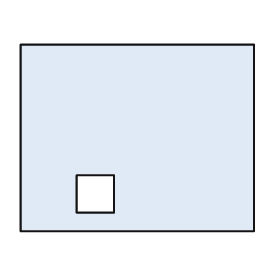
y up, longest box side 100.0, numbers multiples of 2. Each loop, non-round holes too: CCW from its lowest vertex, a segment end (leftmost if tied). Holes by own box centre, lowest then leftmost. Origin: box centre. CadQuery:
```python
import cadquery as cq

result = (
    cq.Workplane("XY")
    .moveTo(-50.0, -40.0)
    .lineTo(50.0, -40.0)
    .lineTo(50.0, 40.0)
    .lineTo(-50.0, 40.0)
    .close()
    .moveTo(-26.0, -32.0)
    .lineTo(-10.0, -32.0)
    .lineTo(-10.0, -16.0)
    .lineTo(-26.0, -16.0)
    .close()
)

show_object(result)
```